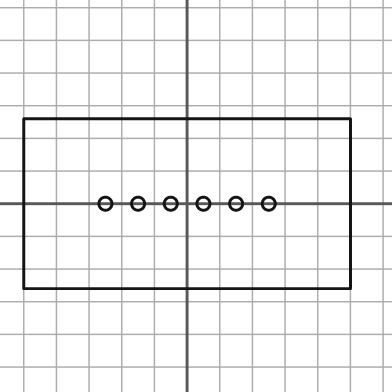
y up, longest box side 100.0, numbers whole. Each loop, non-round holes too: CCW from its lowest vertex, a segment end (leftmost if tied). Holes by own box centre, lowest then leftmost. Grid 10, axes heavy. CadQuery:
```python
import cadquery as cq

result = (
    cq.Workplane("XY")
    .moveTo(-50.0, -26.0)
    .lineTo(50.0, -26.0)
    .lineTo(50.0, 26.0)
    .lineTo(-50.0, 26.0)
    .close()
    .moveTo(-25.0, 0.0)
    .circle(2.0)
    .moveTo(-15.0, 0.0)
    .circle(2.0)
    .moveTo(-5.0, 0.0)
    .circle(2.0)
    .moveTo(5.0, 0.0)
    .circle(2.0)
    .moveTo(15.0, 0.0)
    .circle(2.0)
    .moveTo(25.0, 0.0)
    .circle(2.0)
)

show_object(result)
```